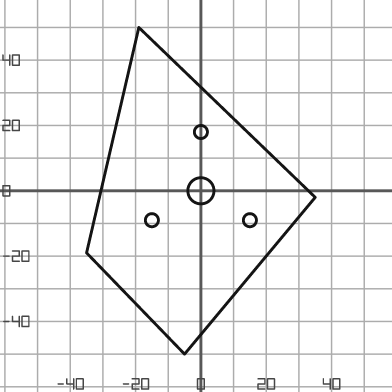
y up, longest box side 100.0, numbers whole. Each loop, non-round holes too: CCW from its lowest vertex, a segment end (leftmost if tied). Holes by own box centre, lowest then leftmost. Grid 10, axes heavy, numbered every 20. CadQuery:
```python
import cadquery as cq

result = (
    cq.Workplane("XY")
    .moveTo(-5.0, -50.0)
    .lineTo(35.0, -2.0)
    .lineTo(-19.0, 50.0)
    .lineTo(-35.0, -19.0)
    .close()
    .moveTo(-15.0, -9.0)
    .circle(2.0)
    .moveTo(15.0, -9.0)
    .circle(2.0)
    .moveTo(0.0, 0.0)
    .circle(4.0)
    .moveTo(0.0, 18.0)
    .circle(2.0)
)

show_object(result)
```